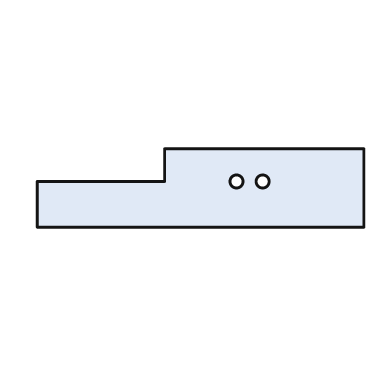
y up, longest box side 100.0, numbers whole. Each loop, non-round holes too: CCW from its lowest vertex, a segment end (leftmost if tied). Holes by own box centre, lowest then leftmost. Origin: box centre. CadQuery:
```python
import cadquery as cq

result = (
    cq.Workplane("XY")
    .moveTo(-50.0, -12.0)
    .lineTo(50.0, -12.0)
    .lineTo(50.0, 12.0)
    .lineTo(-11.0, 12.0)
    .lineTo(-11.0, 2.0)
    .lineTo(-50.0, 2.0)
    .close()
    .moveTo(11.0, 2.0)
    .circle(2.0)
    .moveTo(19.0, 2.0)
    .circle(2.0)
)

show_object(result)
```